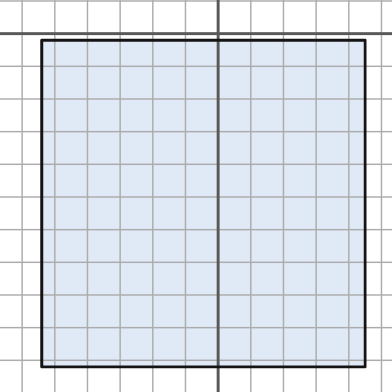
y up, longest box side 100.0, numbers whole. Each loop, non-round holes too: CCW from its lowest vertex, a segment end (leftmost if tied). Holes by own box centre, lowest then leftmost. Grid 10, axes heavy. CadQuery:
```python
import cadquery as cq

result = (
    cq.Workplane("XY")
    .moveTo(-54.0, -102.0)
    .lineTo(45.0, -102.0)
    .lineTo(45.0, -2.0)
    .lineTo(-54.0, -2.0)
    .close()
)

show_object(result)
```